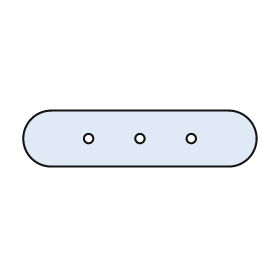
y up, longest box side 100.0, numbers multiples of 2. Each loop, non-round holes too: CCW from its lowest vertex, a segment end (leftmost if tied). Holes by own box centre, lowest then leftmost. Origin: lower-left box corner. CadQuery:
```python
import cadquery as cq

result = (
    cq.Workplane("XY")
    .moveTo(12.0, 0.0)
    .lineTo(88.0, 0.0)
    .threePointArc((100.0, 12.0), (88.0, 24.0))
    .lineTo(12.0, 24.0)
    .threePointArc((0.0, 12.0), (12.0, 0.0))
    .close()
    .moveTo(28.0, 12.0)
    .circle(2.0)
    .moveTo(50.0, 12.0)
    .circle(2.0)
    .moveTo(72.0, 12.0)
    .circle(2.0)
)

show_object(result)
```